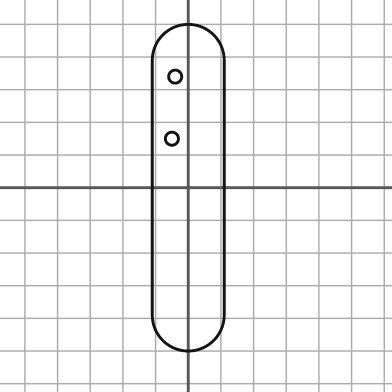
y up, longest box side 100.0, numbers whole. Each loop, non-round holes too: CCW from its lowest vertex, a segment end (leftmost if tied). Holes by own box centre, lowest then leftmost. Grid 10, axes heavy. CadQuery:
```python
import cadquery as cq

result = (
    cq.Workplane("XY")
    .moveTo(-11.0, -39.0)
    .threePointArc((0.0, -50.0), (11.0, -39.0))
    .lineTo(11.0, 39.0)
    .threePointArc((0.0, 50.0), (-11.0, 39.0))
    .close()
    .moveTo(-5.0, 15.0)
    .circle(2.0)
    .moveTo(-4.0, 34.0)
    .circle(2.0)
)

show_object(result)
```